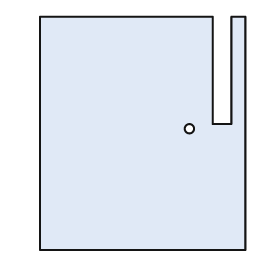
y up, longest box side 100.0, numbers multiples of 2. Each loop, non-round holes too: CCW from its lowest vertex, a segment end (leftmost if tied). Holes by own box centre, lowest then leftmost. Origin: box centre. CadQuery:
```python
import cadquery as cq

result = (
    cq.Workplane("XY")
    .moveTo(-44.0, -50.0)
    .lineTo(44.0, -50.0)
    .lineTo(44.0, 50.0)
    .lineTo(38.0, 50.0)
    .lineTo(38.0, 4.0)
    .lineTo(30.0, 4.0)
    .lineTo(30.0, 50.0)
    .lineTo(-44.0, 50.0)
    .close()
    .moveTo(20.0, 2.0)
    .circle(2.0)
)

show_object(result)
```